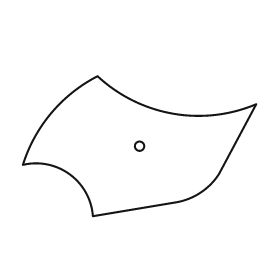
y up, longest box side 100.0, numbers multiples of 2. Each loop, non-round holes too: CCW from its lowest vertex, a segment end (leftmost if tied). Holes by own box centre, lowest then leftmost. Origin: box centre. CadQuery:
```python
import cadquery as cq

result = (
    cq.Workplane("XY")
    .moveTo(-20.0, -30.0)
    .lineTo(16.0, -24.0)
    .threePointArc((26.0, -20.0), (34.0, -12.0))
    .lineTo(50.0, 18.0)
    .threePointArc((14.0, 14.0), (-18.0, 30.0))
    .threePointArc((-38.0, 14.0), (-50.0, -8.0))
    .threePointArc((-30.0, -12.0), (-20.0, -30.0))
    .close()
    .moveTo(0.0, 0.0)
    .circle(2.0)
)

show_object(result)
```